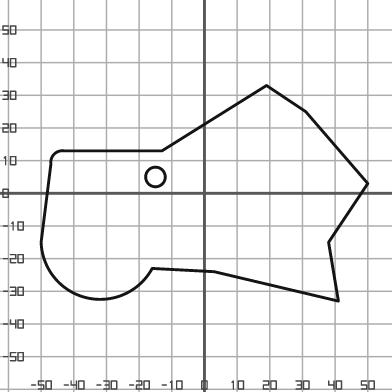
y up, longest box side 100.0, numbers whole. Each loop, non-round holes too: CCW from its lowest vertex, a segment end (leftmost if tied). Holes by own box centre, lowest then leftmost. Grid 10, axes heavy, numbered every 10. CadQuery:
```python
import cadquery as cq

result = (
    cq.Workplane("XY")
    .moveTo(41.0, -33.0)
    .lineTo(38.0, -15.0)
    .lineTo(50.0, 3.0)
    .lineTo(31.0, 25.0)
    .lineTo(19.0, 33.0)
    .lineTo(-13.0, 13.0)
    .lineTo(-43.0, 13.0)
    .threePointArc((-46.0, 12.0), (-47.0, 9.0))
    .lineTo(-50.0, -15.0)
    .threePointArc((-36.0, -32.0), (-16.0, -23.0))
    .lineTo(3.0, -24.0)
    .close()
    .moveTo(-15.0, 5.0)
    .circle(3.0)
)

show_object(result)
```